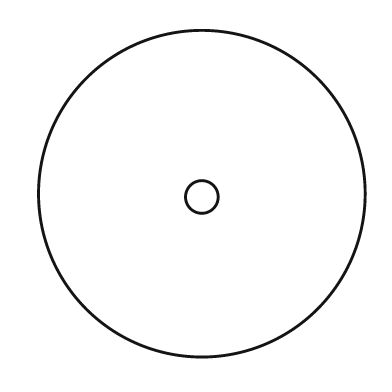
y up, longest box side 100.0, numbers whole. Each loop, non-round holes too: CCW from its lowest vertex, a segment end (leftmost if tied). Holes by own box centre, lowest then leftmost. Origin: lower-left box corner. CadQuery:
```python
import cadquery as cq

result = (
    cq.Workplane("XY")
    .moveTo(50.0, 50.0)
    .circle(50.0)
    .moveTo(50.0, 49.0)
    .circle(5.0)
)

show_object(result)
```